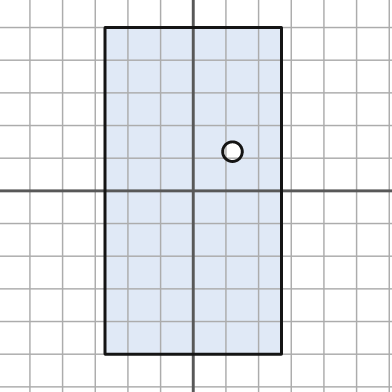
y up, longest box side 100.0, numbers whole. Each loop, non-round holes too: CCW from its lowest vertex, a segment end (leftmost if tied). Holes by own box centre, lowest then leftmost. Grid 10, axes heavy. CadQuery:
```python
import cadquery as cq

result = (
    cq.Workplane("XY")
    .moveTo(-27.0, -50.0)
    .lineTo(27.0, -50.0)
    .lineTo(27.0, 50.0)
    .lineTo(-27.0, 50.0)
    .close()
    .moveTo(12.0, 12.0)
    .circle(3.0)
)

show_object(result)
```